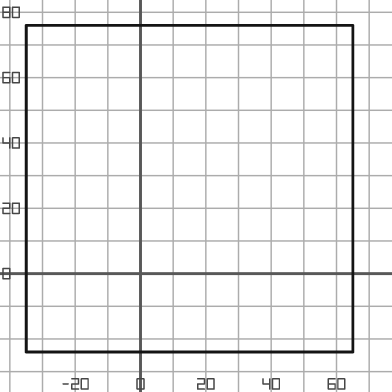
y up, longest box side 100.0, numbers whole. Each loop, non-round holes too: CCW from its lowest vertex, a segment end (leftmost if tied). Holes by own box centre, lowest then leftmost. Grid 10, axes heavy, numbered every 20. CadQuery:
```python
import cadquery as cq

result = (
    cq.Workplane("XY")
    .moveTo(-35.0, -24.0)
    .lineTo(65.0, -24.0)
    .lineTo(65.0, 76.0)
    .lineTo(-35.0, 76.0)
    .close()
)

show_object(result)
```